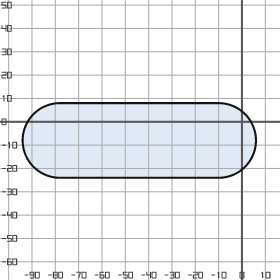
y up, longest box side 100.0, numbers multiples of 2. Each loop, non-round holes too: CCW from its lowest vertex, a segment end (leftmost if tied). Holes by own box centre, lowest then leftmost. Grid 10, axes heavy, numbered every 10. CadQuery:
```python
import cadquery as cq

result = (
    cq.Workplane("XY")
    .moveTo(-78.0, -24.0)
    .lineTo(-10.0, -24.0)
    .threePointArc((6.0, -8.0), (-10.0, 8.0))
    .lineTo(-78.0, 8.0)
    .threePointArc((-94.0, -8.0), (-78.0, -24.0))
    .close()
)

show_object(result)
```